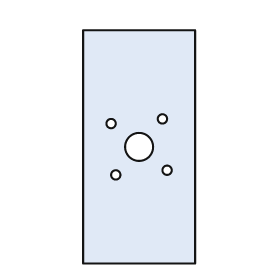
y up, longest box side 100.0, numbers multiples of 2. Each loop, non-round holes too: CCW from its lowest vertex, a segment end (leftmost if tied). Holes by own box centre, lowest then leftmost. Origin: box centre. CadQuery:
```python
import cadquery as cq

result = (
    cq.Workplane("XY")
    .moveTo(-24.0, -50.0)
    .lineTo(24.0, -50.0)
    .lineTo(24.0, 50.0)
    .lineTo(-24.0, 50.0)
    .close()
    .moveTo(-10.0, -12.0)
    .circle(2.0)
    .moveTo(12.0, -10.0)
    .circle(2.0)
    .moveTo(0.0, 0.0)
    .circle(6.0)
    .moveTo(-12.0, 10.0)
    .circle(2.0)
    .moveTo(10.0, 12.0)
    .circle(2.0)
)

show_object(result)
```